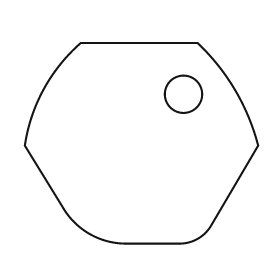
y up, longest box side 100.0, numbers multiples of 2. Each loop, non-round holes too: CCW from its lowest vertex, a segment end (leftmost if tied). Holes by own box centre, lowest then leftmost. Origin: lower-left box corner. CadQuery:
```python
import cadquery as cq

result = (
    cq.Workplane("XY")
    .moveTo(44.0, 0.0)
    .lineTo(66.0, 0.0)
    .threePointArc((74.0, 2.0), (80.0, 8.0))
    .lineTo(100.0, 42.0)
    .threePointArc((90.0, 66.0), (74.0, 86.0))
    .lineTo(24.0, 86.0)
    .threePointArc((8.0, 66.0), (0.0, 42.0))
    .lineTo(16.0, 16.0)
    .threePointArc((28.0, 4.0), (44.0, 0.0))
    .close()
    .moveTo(68.0, 64.0)
    .circle(8.0)
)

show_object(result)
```